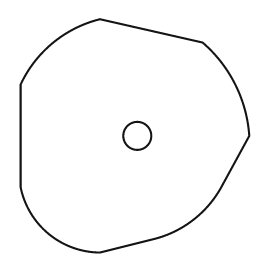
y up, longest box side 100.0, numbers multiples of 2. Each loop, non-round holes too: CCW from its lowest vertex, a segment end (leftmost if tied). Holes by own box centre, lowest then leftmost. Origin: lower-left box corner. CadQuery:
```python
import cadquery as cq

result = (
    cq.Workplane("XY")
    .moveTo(34.0, 0.0)
    .lineTo(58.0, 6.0)
    .threePointArc((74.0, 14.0), (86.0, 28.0))
    .lineTo(98.0, 50.0)
    .threePointArc((92.0, 72.0), (78.0, 90.0))
    .lineTo(34.0, 100.0)
    .threePointArc((14.0, 90.0), (0.0, 72.0))
    .lineTo(0.0, 28.0)
    .threePointArc((12.0, 8.0), (34.0, 0.0))
    .close()
    .moveTo(50.0, 50.0)
    .circle(6.0)
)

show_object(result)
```